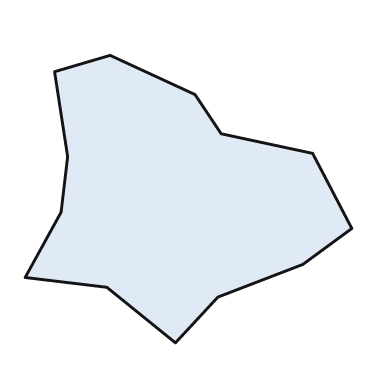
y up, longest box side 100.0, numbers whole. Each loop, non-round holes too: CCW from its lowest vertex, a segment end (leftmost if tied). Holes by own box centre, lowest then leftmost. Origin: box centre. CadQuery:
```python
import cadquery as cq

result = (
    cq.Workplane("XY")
    .moveTo(-4.0, -44.0)
    .lineTo(9.0, -30.0)
    .lineTo(35.0, -20.0)
    .lineTo(50.0, -9.0)
    .lineTo(38.0, 14.0)
    .lineTo(10.0, 20.0)
    .lineTo(2.0, 32.0)
    .lineTo(-24.0, 44.0)
    .lineTo(-41.0, 39.0)
    .lineTo(-37.0, 13.0)
    .lineTo(-39.0, -4.0)
    .lineTo(-50.0, -24.0)
    .lineTo(-25.0, -27.0)
    .close()
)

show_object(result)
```